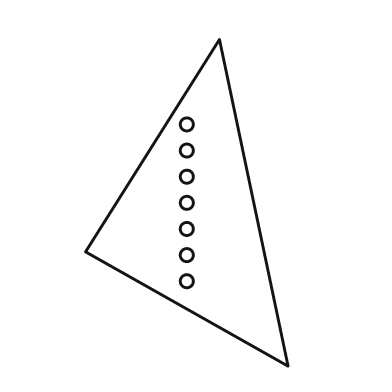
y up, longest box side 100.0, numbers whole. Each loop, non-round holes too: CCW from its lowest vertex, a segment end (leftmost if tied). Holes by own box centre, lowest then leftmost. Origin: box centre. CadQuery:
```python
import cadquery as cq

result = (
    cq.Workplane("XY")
    .moveTo(31.0, -50.0)
    .lineTo(10.0, 50.0)
    .lineTo(-31.0, -15.0)
    .close()
    .moveTo(0.0, -24.0)
    .circle(2.0)
    .moveTo(0.0, -16.0)
    .circle(2.0)
    .moveTo(0.0, -8.0)
    .circle(2.0)
    .moveTo(0.0, 0.0)
    .circle(2.0)
    .moveTo(0.0, 8.0)
    .circle(2.0)
    .moveTo(0.0, 16.0)
    .circle(2.0)
    .moveTo(0.0, 24.0)
    .circle(2.0)
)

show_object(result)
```